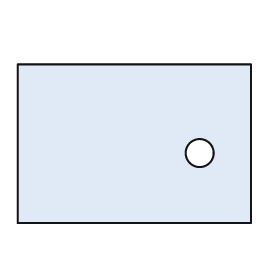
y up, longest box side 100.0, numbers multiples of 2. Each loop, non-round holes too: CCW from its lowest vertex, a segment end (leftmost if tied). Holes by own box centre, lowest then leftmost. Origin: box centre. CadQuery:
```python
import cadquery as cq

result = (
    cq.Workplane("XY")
    .moveTo(-50.0, -34.0)
    .lineTo(50.0, -34.0)
    .lineTo(50.0, 34.0)
    .lineTo(-50.0, 34.0)
    .close()
    .moveTo(28.0, -4.0)
    .circle(6.0)
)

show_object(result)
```